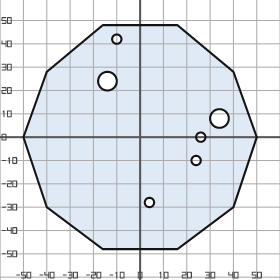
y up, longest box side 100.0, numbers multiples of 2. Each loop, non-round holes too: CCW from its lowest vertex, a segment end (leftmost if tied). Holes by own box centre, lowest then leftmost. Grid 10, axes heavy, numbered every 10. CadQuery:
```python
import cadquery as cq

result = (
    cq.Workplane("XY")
    .moveTo(-16.0, -48.0)
    .lineTo(16.0, -48.0)
    .lineTo(40.0, -30.0)
    .lineTo(50.0, 0.0)
    .lineTo(40.0, 28.0)
    .lineTo(16.0, 48.0)
    .lineTo(-16.0, 48.0)
    .lineTo(-40.0, 28.0)
    .lineTo(-50.0, 0.0)
    .lineTo(-40.0, -30.0)
    .close()
    .moveTo(4.0, -28.0)
    .circle(2.0)
    .moveTo(24.0, -10.0)
    .circle(2.0)
    .moveTo(26.0, 0.0)
    .circle(2.0)
    .moveTo(34.0, 8.0)
    .circle(4.0)
    .moveTo(-14.0, 24.0)
    .circle(4.0)
    .moveTo(-10.0, 42.0)
    .circle(2.0)
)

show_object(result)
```